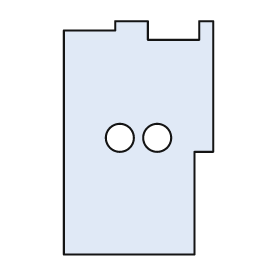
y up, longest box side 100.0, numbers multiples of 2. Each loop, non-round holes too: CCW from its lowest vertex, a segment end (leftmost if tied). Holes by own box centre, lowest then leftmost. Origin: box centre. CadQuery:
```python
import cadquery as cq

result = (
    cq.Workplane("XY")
    .moveTo(-32.0, -50.0)
    .lineTo(24.0, -50.0)
    .lineTo(24.0, -6.0)
    .lineTo(32.0, -6.0)
    .lineTo(32.0, 50.0)
    .lineTo(26.0, 50.0)
    .lineTo(26.0, 42.0)
    .lineTo(4.0, 42.0)
    .lineTo(4.0, 50.0)
    .lineTo(-10.0, 50.0)
    .lineTo(-10.0, 46.0)
    .lineTo(-32.0, 46.0)
    .close()
    .moveTo(-8.0, 0.0)
    .circle(6.0)
    .moveTo(8.0, 0.0)
    .circle(6.0)
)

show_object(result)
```